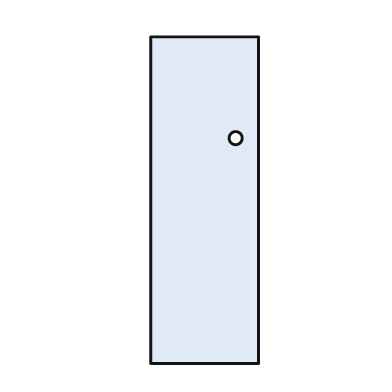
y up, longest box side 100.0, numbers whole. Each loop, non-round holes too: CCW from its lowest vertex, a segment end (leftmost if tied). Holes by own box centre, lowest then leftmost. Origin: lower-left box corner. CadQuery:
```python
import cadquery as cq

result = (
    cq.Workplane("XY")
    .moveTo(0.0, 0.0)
    .lineTo(33.0, 0.0)
    .lineTo(33.0, 100.0)
    .lineTo(0.0, 100.0)
    .close()
    .moveTo(26.0, 69.0)
    .circle(2.0)
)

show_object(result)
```